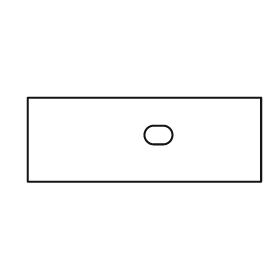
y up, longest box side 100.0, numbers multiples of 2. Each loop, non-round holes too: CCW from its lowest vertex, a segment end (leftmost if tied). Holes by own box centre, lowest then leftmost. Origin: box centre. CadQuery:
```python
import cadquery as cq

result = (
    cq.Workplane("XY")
    .moveTo(-50.0, -18.0)
    .lineTo(50.0, -18.0)
    .lineTo(50.0, 18.0)
    .lineTo(-50.0, 18.0)
    .close()
    .moveTo(4.0, -2.0)
    .lineTo(8.0, -2.0)
    .threePointArc((12.0, 2.0), (8.0, 6.0))
    .lineTo(4.0, 6.0)
    .threePointArc((0.0, 2.0), (4.0, -2.0))
    .close()
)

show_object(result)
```